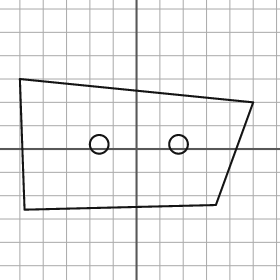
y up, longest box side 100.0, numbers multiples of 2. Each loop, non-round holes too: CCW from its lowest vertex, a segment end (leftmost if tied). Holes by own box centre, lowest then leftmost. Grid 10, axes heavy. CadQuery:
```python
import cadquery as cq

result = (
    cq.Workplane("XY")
    .moveTo(-48.0, -26.0)
    .lineTo(34.0, -24.0)
    .lineTo(50.0, 20.0)
    .lineTo(-50.0, 30.0)
    .close()
    .moveTo(-16.0, 2.0)
    .circle(4.0)
    .moveTo(18.0, 2.0)
    .circle(4.0)
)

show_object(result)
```